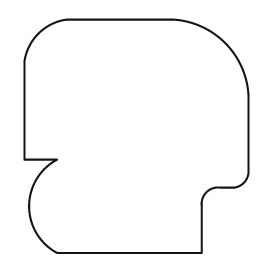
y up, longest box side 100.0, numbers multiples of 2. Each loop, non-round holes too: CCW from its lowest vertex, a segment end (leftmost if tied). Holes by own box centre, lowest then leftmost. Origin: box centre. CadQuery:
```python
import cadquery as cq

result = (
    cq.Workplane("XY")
    .moveTo(-34.0, -50.0)
    .lineTo(28.0, -50.0)
    .lineTo(28.0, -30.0)
    .threePointArc((30.0, -24.0), (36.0, -22.0))
    .lineTo(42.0, -22.0)
    .threePointArc((46.0, -20.0), (48.0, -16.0))
    .lineTo(48.0, 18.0)
    .threePointArc((38.0, 40.0), (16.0, 50.0))
    .lineTo(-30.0, 50.0)
    .threePointArc((-42.0, 44.0), (-48.0, 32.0))
    .lineTo(-48.0, -10.0)
    .lineTo(-34.0, -10.0)
    .threePointArc((-46.0, -30.0), (-34.0, -50.0))
    .close()
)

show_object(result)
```